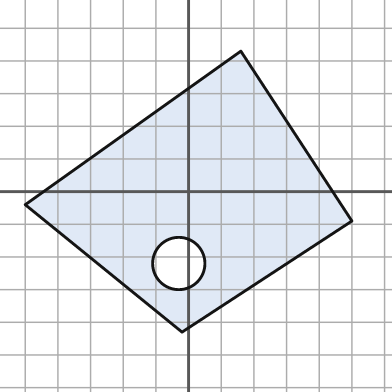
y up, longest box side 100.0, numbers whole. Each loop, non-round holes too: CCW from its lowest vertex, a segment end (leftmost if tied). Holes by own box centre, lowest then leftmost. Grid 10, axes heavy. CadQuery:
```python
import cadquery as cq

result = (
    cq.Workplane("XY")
    .moveTo(-2.0, -43.0)
    .lineTo(50.0, -9.0)
    .lineTo(16.0, 43.0)
    .lineTo(-50.0, -4.0)
    .close()
    .moveTo(-3.0, -22.0)
    .circle(8.0)
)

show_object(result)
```